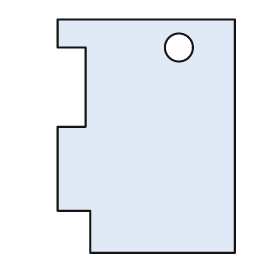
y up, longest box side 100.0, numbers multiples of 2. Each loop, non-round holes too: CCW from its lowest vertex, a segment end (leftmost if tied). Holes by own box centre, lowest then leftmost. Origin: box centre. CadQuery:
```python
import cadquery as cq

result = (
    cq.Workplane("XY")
    .moveTo(-24.0, -50.0)
    .lineTo(38.0, -50.0)
    .lineTo(38.0, 50.0)
    .lineTo(-38.0, 50.0)
    .lineTo(-38.0, 38.0)
    .lineTo(-26.0, 38.0)
    .lineTo(-26.0, 4.0)
    .lineTo(-38.0, 4.0)
    .lineTo(-38.0, -32.0)
    .lineTo(-24.0, -32.0)
    .close()
    .moveTo(14.0, 38.0)
    .circle(6.0)
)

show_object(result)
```